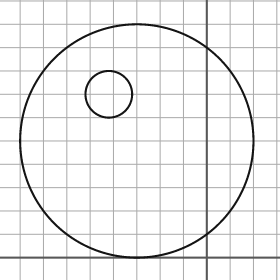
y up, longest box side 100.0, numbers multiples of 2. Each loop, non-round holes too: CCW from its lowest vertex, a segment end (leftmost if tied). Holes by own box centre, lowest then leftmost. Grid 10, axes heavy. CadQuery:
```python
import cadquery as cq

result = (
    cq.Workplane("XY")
    .moveTo(-30.0, 50.0)
    .circle(50.0)
    .moveTo(-42.0, 70.0)
    .circle(10.0)
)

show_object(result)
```